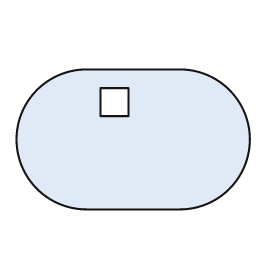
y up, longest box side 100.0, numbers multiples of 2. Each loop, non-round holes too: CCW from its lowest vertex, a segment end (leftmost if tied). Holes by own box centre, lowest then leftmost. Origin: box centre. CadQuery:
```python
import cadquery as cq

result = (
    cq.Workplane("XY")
    .moveTo(-20.0, -30.0)
    .lineTo(20.0, -30.0)
    .threePointArc((50.0, 0.0), (20.0, 30.0))
    .lineTo(-20.0, 30.0)
    .threePointArc((-50.0, 0.0), (-20.0, -30.0))
    .close()
    .moveTo(-14.0, 10.0)
    .lineTo(-2.0, 10.0)
    .lineTo(-2.0, 22.0)
    .lineTo(-14.0, 22.0)
    .close()
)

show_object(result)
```